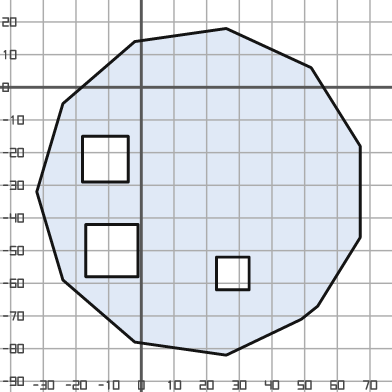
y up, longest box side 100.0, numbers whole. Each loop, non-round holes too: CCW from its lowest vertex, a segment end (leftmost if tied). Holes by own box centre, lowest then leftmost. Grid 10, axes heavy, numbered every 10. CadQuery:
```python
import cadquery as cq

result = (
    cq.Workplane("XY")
    .moveTo(26.0, -82.0)
    .lineTo(49.0, -71.0)
    .lineTo(54.0, -67.0)
    .lineTo(67.0, -46.0)
    .lineTo(67.0, -18.0)
    .lineTo(52.0, 6.0)
    .lineTo(26.0, 18.0)
    .lineTo(-2.0, 14.0)
    .lineTo(-24.0, -5.0)
    .lineTo(-32.0, -32.0)
    .lineTo(-24.0, -59.0)
    .lineTo(-2.0, -78.0)
    .close()
    .moveTo(23.0, -62.0)
    .lineTo(33.0, -62.0)
    .lineTo(33.0, -52.0)
    .lineTo(23.0, -52.0)
    .close()
    .moveTo(-17.0, -58.0)
    .lineTo(-1.0, -58.0)
    .lineTo(-1.0, -42.0)
    .lineTo(-17.0, -42.0)
    .close()
    .moveTo(-18.0, -29.0)
    .lineTo(-4.0, -29.0)
    .lineTo(-4.0, -15.0)
    .lineTo(-18.0, -15.0)
    .close()
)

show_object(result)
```